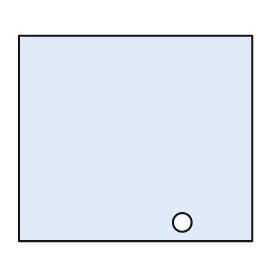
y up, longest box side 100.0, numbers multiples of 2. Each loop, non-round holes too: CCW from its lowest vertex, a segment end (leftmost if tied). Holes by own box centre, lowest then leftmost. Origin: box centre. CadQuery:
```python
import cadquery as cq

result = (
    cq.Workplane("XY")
    .moveTo(-50.0, -44.0)
    .lineTo(50.0, -44.0)
    .lineTo(50.0, 44.0)
    .lineTo(-50.0, 44.0)
    .close()
    .moveTo(20.0, -36.0)
    .circle(4.0)
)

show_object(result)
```